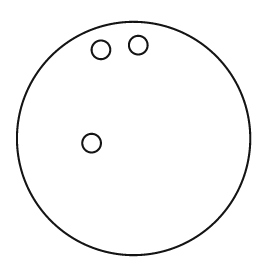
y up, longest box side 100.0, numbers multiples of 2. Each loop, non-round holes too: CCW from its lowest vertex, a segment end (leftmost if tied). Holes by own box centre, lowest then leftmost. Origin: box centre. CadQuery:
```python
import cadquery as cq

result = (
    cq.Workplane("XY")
    .moveTo(0.0, 0.0)
    .circle(50.0)
    .moveTo(-18.0, -2.0)
    .circle(4.0)
    .moveTo(-14.0, 38.0)
    .circle(4.0)
    .moveTo(2.0, 40.0)
    .circle(4.0)
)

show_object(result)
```